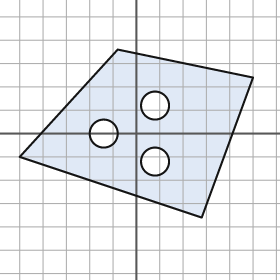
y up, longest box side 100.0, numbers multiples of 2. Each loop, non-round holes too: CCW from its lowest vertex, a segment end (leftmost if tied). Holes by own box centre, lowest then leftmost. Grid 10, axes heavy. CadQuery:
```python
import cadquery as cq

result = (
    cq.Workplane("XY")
    .moveTo(28.0, -36.0)
    .lineTo(50.0, 24.0)
    .lineTo(-8.0, 36.0)
    .lineTo(-50.0, -10.0)
    .close()
    .moveTo(8.0, -12.0)
    .circle(6.0)
    .moveTo(-14.0, 0.0)
    .circle(6.0)
    .moveTo(8.0, 12.0)
    .circle(6.0)
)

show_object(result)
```